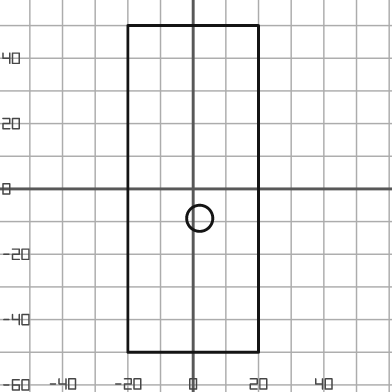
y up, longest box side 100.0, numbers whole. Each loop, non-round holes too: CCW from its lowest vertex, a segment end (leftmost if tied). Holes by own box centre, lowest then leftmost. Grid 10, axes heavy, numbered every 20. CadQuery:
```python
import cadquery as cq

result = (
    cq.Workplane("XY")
    .moveTo(-20.0, -50.0)
    .lineTo(20.0, -50.0)
    .lineTo(20.0, 50.0)
    .lineTo(-20.0, 50.0)
    .close()
    .moveTo(2.0, -9.0)
    .circle(4.0)
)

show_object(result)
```